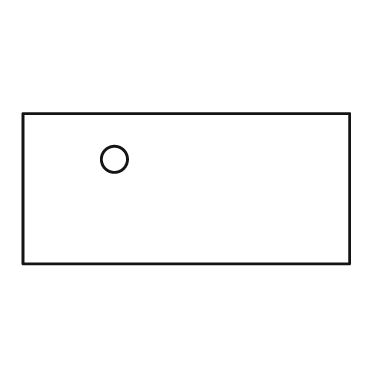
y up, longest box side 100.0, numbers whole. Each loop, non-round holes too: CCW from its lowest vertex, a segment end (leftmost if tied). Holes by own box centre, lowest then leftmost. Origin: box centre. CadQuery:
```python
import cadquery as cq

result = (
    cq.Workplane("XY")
    .moveTo(-50.0, -23.0)
    .lineTo(50.0, -23.0)
    .lineTo(50.0, 23.0)
    .lineTo(-50.0, 23.0)
    .close()
    .moveTo(-22.0, 9.0)
    .circle(4.0)
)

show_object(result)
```